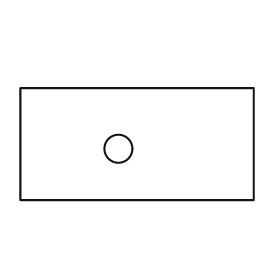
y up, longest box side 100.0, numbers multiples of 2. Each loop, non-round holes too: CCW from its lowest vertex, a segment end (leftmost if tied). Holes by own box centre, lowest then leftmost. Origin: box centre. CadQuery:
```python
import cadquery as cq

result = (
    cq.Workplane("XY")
    .moveTo(-50.0, -24.0)
    .lineTo(50.0, -24.0)
    .lineTo(50.0, 24.0)
    .lineTo(-50.0, 24.0)
    .close()
    .moveTo(-8.0, -2.0)
    .circle(6.0)
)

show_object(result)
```